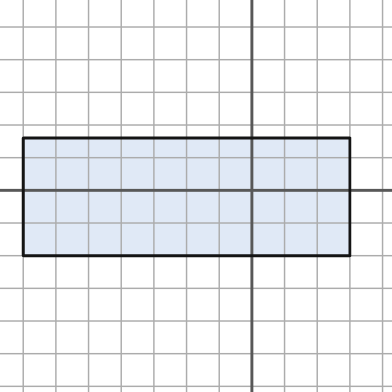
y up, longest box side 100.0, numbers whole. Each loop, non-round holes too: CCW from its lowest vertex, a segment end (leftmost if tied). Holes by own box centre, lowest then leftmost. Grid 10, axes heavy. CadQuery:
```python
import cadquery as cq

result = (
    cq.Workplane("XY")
    .moveTo(-70.0, -20.0)
    .lineTo(30.0, -20.0)
    .lineTo(30.0, 16.0)
    .lineTo(-70.0, 16.0)
    .close()
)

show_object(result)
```